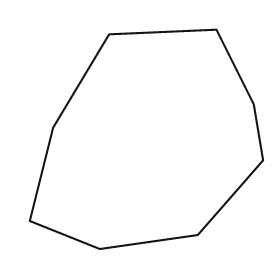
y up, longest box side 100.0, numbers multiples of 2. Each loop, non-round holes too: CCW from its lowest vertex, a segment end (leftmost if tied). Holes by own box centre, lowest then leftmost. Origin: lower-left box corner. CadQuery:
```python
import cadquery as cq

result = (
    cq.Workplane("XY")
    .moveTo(30.0, 0.0)
    .lineTo(72.0, 6.0)
    .lineTo(100.0, 38.0)
    .lineTo(96.0, 62.0)
    .lineTo(80.0, 94.0)
    .lineTo(34.0, 92.0)
    .lineTo(10.0, 52.0)
    .lineTo(0.0, 12.0)
    .close()
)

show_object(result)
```